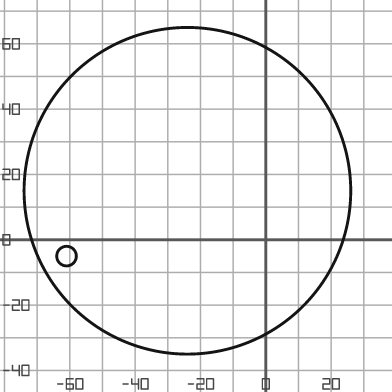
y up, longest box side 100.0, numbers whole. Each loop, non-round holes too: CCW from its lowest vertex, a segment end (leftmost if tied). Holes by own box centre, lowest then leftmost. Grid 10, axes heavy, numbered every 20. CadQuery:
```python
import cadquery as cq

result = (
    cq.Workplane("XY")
    .moveTo(-24.0, 15.0)
    .circle(50.0)
    .moveTo(-61.0, -5.0)
    .circle(3.0)
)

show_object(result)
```